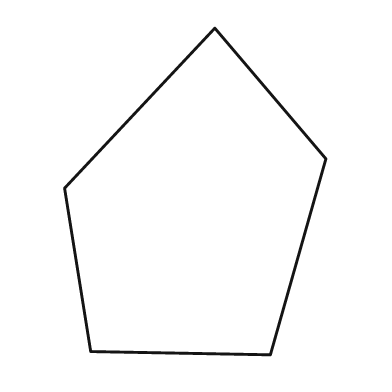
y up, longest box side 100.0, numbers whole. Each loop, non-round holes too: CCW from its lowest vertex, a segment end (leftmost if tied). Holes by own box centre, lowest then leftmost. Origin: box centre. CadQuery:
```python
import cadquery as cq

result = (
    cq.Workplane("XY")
    .moveTo(23.0, -50.0)
    .lineTo(40.0, 10.0)
    .lineTo(6.0, 50.0)
    .lineTo(-40.0, 1.0)
    .lineTo(-32.0, -49.0)
    .close()
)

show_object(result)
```